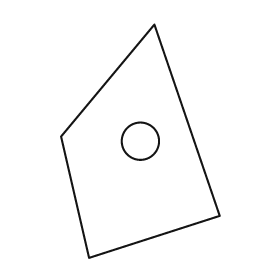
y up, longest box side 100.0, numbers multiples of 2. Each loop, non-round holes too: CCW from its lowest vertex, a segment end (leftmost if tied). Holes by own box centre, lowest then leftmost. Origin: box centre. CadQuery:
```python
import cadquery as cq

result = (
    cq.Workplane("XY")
    .moveTo(-22.0, -50.0)
    .lineTo(34.0, -32.0)
    .lineTo(6.0, 50.0)
    .lineTo(-34.0, 2.0)
    .close()
    .moveTo(0.0, 0.0)
    .circle(8.0)
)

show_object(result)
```